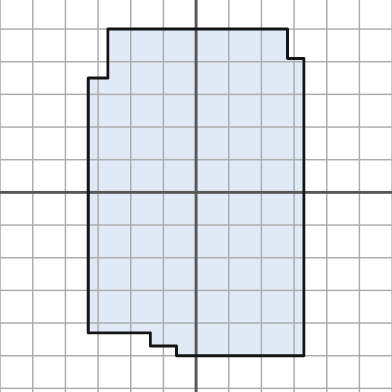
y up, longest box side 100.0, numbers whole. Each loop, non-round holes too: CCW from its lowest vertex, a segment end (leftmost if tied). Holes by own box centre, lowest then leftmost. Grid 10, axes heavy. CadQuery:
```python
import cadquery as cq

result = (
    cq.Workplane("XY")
    .moveTo(-6.0, -50.0)
    .lineTo(33.0, -50.0)
    .lineTo(33.0, 41.0)
    .lineTo(28.0, 41.0)
    .lineTo(28.0, 50.0)
    .lineTo(-27.0, 50.0)
    .lineTo(-27.0, 35.0)
    .lineTo(-33.0, 35.0)
    .lineTo(-33.0, -43.0)
    .lineTo(-14.0, -43.0)
    .lineTo(-14.0, -47.0)
    .lineTo(-6.0, -47.0)
    .close()
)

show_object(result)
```